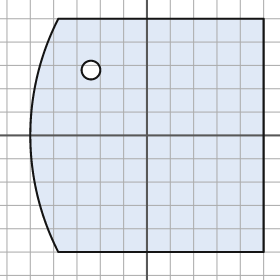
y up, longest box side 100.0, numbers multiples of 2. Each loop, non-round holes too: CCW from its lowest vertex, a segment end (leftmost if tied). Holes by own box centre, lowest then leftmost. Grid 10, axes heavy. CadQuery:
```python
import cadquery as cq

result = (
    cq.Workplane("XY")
    .moveTo(-38.0, -50.0)
    .lineTo(50.0, -50.0)
    .lineTo(50.0, 50.0)
    .lineTo(-38.0, 50.0)
    .threePointArc((-50.0, 0.0), (-38.0, -50.0))
    .close()
    .moveTo(-24.0, 28.0)
    .circle(4.0)
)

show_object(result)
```